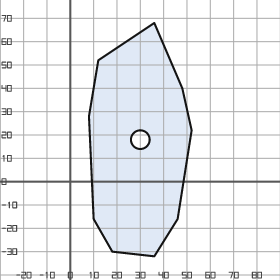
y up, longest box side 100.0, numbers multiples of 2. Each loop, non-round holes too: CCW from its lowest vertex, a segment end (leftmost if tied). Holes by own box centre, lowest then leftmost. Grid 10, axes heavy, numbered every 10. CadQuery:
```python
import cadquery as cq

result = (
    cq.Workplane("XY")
    .moveTo(36.0, -32.0)
    .lineTo(46.0, -16.0)
    .lineTo(52.0, 22.0)
    .lineTo(48.0, 40.0)
    .lineTo(36.0, 68.0)
    .lineTo(12.0, 52.0)
    .lineTo(8.0, 28.0)
    .lineTo(10.0, -16.0)
    .lineTo(18.0, -30.0)
    .close()
    .moveTo(30.0, 18.0)
    .circle(4.0)
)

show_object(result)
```